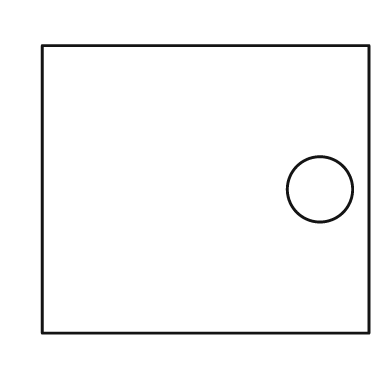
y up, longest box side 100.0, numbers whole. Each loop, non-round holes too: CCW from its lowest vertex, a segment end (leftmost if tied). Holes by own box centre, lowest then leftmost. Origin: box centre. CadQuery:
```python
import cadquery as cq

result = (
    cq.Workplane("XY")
    .moveTo(-50.0, -44.0)
    .lineTo(50.0, -44.0)
    .lineTo(50.0, 44.0)
    .lineTo(-50.0, 44.0)
    .close()
    .moveTo(35.0, 0.0)
    .circle(10.0)
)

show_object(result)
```